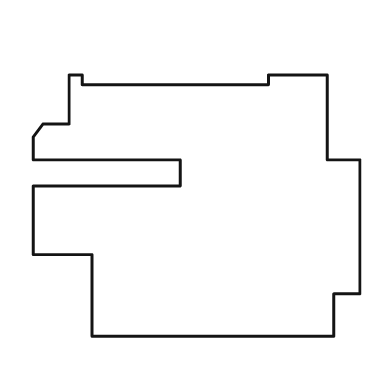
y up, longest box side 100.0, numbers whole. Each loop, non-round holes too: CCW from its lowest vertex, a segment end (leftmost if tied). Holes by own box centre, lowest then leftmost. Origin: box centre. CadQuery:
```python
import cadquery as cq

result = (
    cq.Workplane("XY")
    .moveTo(-32.0, -40.0)
    .lineTo(42.0, -40.0)
    .lineTo(42.0, -27.0)
    .lineTo(50.0, -27.0)
    .lineTo(50.0, 14.0)
    .lineTo(40.0, 14.0)
    .lineTo(40.0, 40.0)
    .lineTo(22.0, 40.0)
    .lineTo(22.0, 37.0)
    .lineTo(-35.0, 37.0)
    .lineTo(-35.0, 40.0)
    .lineTo(-39.0, 40.0)
    .lineTo(-39.0, 25.0)
    .lineTo(-47.0, 25.0)
    .lineTo(-50.0, 21.0)
    .lineTo(-50.0, 14.0)
    .lineTo(-5.0, 14.0)
    .lineTo(-5.0, 6.0)
    .lineTo(-50.0, 6.0)
    .lineTo(-50.0, -15.0)
    .lineTo(-32.0, -15.0)
    .close()
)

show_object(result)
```